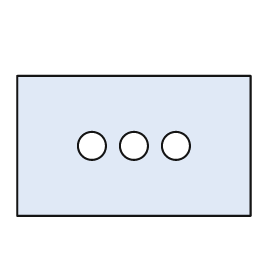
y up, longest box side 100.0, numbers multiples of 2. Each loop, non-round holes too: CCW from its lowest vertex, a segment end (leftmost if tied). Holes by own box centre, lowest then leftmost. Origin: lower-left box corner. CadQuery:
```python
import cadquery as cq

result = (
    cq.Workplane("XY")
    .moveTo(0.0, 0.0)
    .lineTo(100.0, 0.0)
    .lineTo(100.0, 60.0)
    .lineTo(0.0, 60.0)
    .close()
    .moveTo(32.0, 30.0)
    .circle(6.0)
    .moveTo(50.0, 30.0)
    .circle(6.0)
    .moveTo(68.0, 30.0)
    .circle(6.0)
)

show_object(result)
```